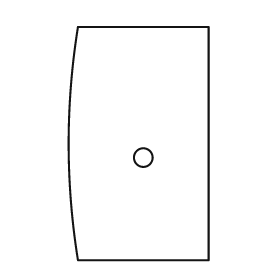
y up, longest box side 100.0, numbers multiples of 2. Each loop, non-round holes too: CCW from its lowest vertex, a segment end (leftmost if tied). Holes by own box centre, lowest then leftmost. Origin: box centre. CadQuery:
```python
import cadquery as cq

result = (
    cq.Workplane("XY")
    .moveTo(-26.0, -50.0)
    .lineTo(30.0, -50.0)
    .lineTo(30.0, 50.0)
    .lineTo(-26.0, 50.0)
    .threePointArc((-30.0, 0.0), (-26.0, -50.0))
    .close()
    .moveTo(2.0, -6.0)
    .circle(4.0)
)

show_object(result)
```